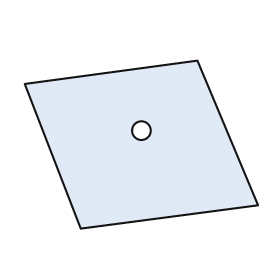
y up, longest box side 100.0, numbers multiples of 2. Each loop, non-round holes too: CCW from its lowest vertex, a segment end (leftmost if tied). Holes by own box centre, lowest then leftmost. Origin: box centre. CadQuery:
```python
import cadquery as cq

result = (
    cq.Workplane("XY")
    .moveTo(-26.0, -36.0)
    .lineTo(50.0, -26.0)
    .lineTo(24.0, 36.0)
    .lineTo(-50.0, 26.0)
    .close()
    .moveTo(0.0, 6.0)
    .circle(4.0)
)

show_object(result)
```